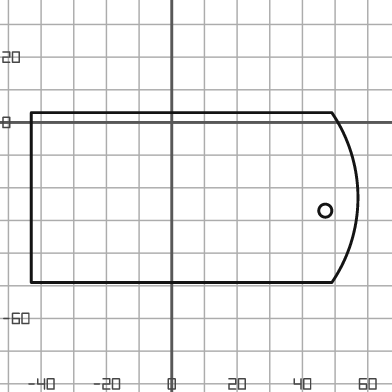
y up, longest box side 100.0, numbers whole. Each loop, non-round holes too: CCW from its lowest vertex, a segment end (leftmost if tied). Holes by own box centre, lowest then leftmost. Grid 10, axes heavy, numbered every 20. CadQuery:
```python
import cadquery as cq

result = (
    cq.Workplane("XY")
    .moveTo(-43.0, -49.0)
    .lineTo(49.0, -49.0)
    .threePointArc((57.0, -23.0), (49.0, 3.0))
    .lineTo(-43.0, 3.0)
    .close()
    .moveTo(47.0, -27.0)
    .circle(2.0)
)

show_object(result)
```